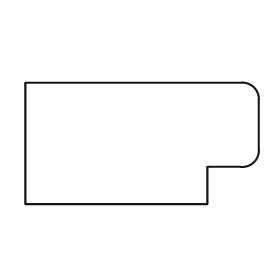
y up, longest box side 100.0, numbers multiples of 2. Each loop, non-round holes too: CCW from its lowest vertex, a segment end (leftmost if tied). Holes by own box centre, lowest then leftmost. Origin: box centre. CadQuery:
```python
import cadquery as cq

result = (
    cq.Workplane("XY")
    .moveTo(-50.0, -26.0)
    .lineTo(28.0, -26.0)
    .lineTo(28.0, -10.0)
    .lineTo(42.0, -10.0)
    .threePointArc((48.0, -8.0), (50.0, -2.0))
    .lineTo(50.0, 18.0)
    .threePointArc((48.0, 24.0), (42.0, 26.0))
    .lineTo(-50.0, 26.0)
    .close()
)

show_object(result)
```